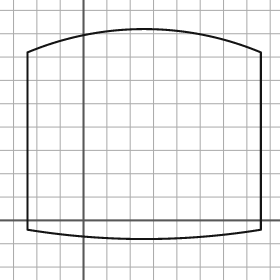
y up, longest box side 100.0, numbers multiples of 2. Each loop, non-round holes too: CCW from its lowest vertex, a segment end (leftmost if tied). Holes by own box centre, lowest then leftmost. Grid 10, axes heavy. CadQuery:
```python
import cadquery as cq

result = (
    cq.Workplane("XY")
    .moveTo(-24.0, -4.0)
    .threePointArc((26.0, -8.0), (76.0, -4.0))
    .lineTo(76.0, 72.0)
    .threePointArc((26.0, 82.0), (-24.0, 72.0))
    .close()
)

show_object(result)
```